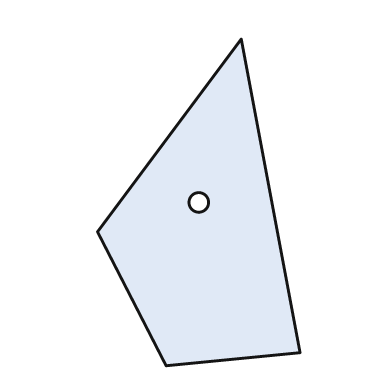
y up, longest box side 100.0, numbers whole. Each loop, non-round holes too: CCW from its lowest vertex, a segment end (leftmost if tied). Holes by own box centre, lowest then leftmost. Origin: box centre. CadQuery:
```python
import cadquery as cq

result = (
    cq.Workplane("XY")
    .moveTo(-10.0, -50.0)
    .lineTo(31.0, -46.0)
    .lineTo(13.0, 50.0)
    .lineTo(-31.0, -9.0)
    .close()
    .moveTo(0.0, 0.0)
    .circle(3.0)
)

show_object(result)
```